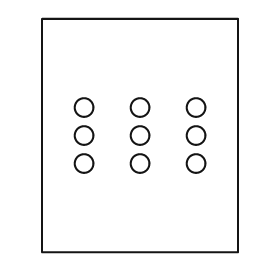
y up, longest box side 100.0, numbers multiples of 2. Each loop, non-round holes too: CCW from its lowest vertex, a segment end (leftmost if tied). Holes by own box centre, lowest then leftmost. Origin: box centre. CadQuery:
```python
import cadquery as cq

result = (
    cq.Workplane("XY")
    .moveTo(-42.0, -50.0)
    .lineTo(42.0, -50.0)
    .lineTo(42.0, 50.0)
    .lineTo(-42.0, 50.0)
    .close()
    .moveTo(-24.0, -12.0)
    .circle(4.0)
    .moveTo(0.0, -12.0)
    .circle(4.0)
    .moveTo(24.0, -12.0)
    .circle(4.0)
    .moveTo(-24.0, 0.0)
    .circle(4.0)
    .moveTo(0.0, 0.0)
    .circle(4.0)
    .moveTo(24.0, 0.0)
    .circle(4.0)
    .moveTo(-24.0, 12.0)
    .circle(4.0)
    .moveTo(0.0, 12.0)
    .circle(4.0)
    .moveTo(24.0, 12.0)
    .circle(4.0)
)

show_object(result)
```